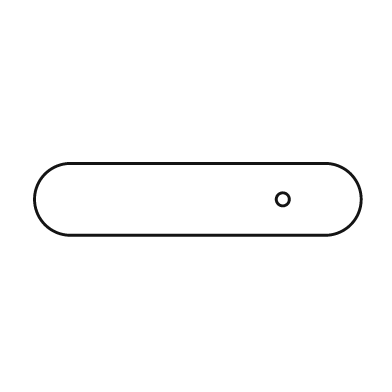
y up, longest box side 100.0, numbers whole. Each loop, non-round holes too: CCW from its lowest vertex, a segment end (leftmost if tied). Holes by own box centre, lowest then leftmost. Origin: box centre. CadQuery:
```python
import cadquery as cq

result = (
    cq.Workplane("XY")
    .moveTo(-39.0, -11.0)
    .lineTo(39.0, -11.0)
    .threePointArc((50.0, 0.0), (39.0, 11.0))
    .lineTo(-39.0, 11.0)
    .threePointArc((-50.0, 0.0), (-39.0, -11.0))
    .close()
    .moveTo(26.0, 0.0)
    .circle(2.0)
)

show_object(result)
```